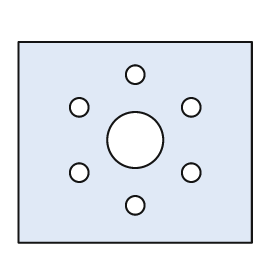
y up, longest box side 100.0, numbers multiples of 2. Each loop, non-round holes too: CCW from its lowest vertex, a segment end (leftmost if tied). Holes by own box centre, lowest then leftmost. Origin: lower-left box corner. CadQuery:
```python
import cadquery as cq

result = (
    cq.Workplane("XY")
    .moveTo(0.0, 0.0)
    .lineTo(100.0, 0.0)
    .lineTo(100.0, 86.0)
    .lineTo(0.0, 86.0)
    .close()
    .moveTo(50.0, 16.0)
    .circle(4.0)
    .moveTo(26.0, 30.0)
    .circle(4.0)
    .moveTo(74.0, 30.0)
    .circle(4.0)
    .moveTo(50.0, 44.0)
    .circle(12.0)
    .moveTo(26.0, 58.0)
    .circle(4.0)
    .moveTo(74.0, 58.0)
    .circle(4.0)
    .moveTo(50.0, 72.0)
    .circle(4.0)
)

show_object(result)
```